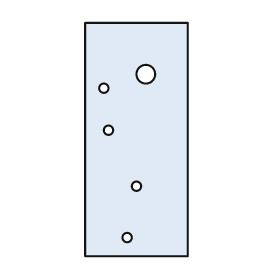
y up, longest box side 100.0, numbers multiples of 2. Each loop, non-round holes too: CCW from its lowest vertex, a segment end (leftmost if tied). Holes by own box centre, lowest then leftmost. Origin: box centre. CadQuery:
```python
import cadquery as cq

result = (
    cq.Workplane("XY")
    .moveTo(-22.0, -50.0)
    .lineTo(22.0, -50.0)
    .lineTo(22.0, 50.0)
    .lineTo(-22.0, 50.0)
    .close()
    .moveTo(-4.0, -42.0)
    .circle(2.0)
    .moveTo(0.0, -20.0)
    .circle(2.0)
    .moveTo(-12.0, 4.0)
    .circle(2.0)
    .moveTo(-14.0, 22.0)
    .circle(2.0)
    .moveTo(4.0, 28.0)
    .circle(4.0)
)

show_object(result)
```